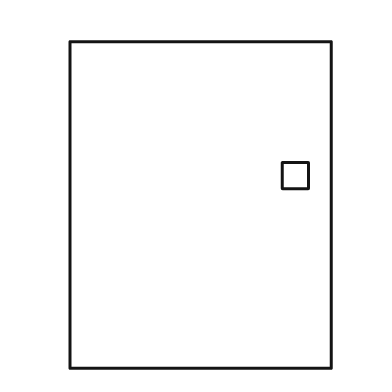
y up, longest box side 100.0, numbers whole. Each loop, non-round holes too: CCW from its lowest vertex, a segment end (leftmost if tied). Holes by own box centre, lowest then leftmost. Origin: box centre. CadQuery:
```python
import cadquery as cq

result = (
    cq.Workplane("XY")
    .moveTo(-40.0, -50.0)
    .lineTo(40.0, -50.0)
    .lineTo(40.0, 50.0)
    .lineTo(-40.0, 50.0)
    .close()
    .moveTo(25.0, 5.0)
    .lineTo(33.0, 5.0)
    .lineTo(33.0, 13.0)
    .lineTo(25.0, 13.0)
    .close()
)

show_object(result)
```